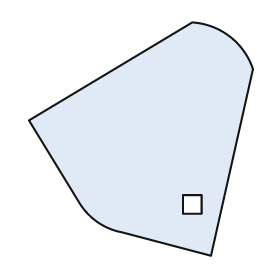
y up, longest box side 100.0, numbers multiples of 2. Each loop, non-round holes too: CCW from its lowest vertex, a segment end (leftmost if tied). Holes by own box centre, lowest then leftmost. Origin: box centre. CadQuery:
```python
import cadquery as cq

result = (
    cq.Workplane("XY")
    .moveTo(30.0, -50.0)
    .lineTo(48.0, 30.0)
    .threePointArc((38.0, 44.0), (22.0, 50.0))
    .lineTo(-48.0, 8.0)
    .lineTo(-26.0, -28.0)
    .threePointArc((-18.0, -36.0), (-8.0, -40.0))
    .close()
    .moveTo(18.0, -32.0)
    .lineTo(26.0, -32.0)
    .lineTo(26.0, -24.0)
    .lineTo(18.0, -24.0)
    .close()
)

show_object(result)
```